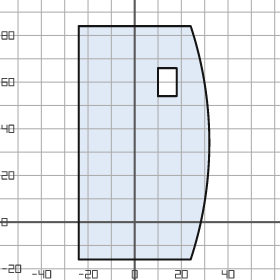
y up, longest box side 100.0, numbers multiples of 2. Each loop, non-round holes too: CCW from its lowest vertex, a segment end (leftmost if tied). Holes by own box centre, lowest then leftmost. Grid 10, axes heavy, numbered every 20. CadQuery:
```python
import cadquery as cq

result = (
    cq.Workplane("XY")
    .moveTo(-24.0, -16.0)
    .lineTo(24.0, -16.0)
    .threePointArc((32.0, 34.0), (24.0, 84.0))
    .lineTo(-24.0, 84.0)
    .close()
    .moveTo(10.0, 54.0)
    .lineTo(18.0, 54.0)
    .lineTo(18.0, 66.0)
    .lineTo(10.0, 66.0)
    .close()
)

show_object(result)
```